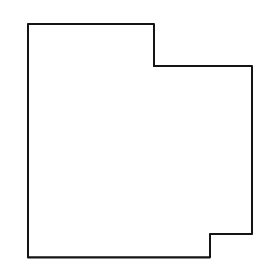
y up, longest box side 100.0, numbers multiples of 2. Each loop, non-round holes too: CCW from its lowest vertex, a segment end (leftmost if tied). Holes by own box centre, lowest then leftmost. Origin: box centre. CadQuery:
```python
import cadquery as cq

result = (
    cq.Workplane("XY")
    .moveTo(-48.0, -50.0)
    .lineTo(30.0, -50.0)
    .lineTo(30.0, -40.0)
    .lineTo(48.0, -40.0)
    .lineTo(48.0, 32.0)
    .lineTo(6.0, 32.0)
    .lineTo(6.0, 50.0)
    .lineTo(-48.0, 50.0)
    .close()
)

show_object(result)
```